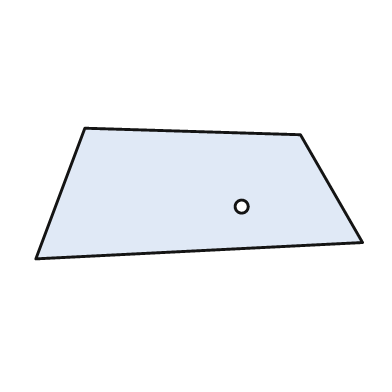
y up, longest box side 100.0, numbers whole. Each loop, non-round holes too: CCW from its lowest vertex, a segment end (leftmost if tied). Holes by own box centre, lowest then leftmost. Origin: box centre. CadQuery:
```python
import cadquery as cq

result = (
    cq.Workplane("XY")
    .moveTo(-50.0, -20.0)
    .lineTo(50.0, -15.0)
    .lineTo(31.0, 18.0)
    .lineTo(-35.0, 20.0)
    .close()
    .moveTo(13.0, -4.0)
    .circle(2.0)
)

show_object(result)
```